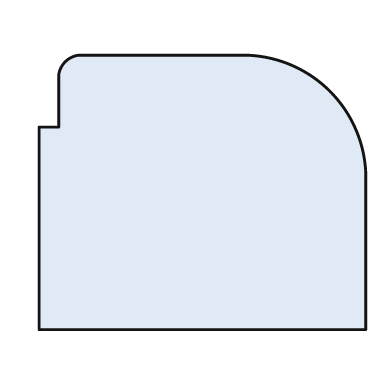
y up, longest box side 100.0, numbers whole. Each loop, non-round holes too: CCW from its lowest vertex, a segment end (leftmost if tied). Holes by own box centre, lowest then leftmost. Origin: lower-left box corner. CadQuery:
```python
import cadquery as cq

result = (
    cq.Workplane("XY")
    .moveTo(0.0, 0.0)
    .lineTo(100.0, 0.0)
    .lineTo(100.0, 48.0)
    .threePointArc((89.0, 73.0), (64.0, 84.0))
    .lineTo(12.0, 84.0)
    .threePointArc((8.0, 82.0), (6.0, 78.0))
    .lineTo(6.0, 62.0)
    .lineTo(0.0, 62.0)
    .close()
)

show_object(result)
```